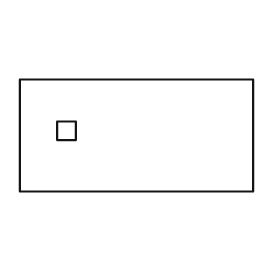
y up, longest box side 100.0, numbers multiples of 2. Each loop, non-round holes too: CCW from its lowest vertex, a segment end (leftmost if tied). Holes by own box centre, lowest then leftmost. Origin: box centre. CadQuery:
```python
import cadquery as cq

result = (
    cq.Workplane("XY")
    .moveTo(-50.0, -24.0)
    .lineTo(50.0, -24.0)
    .lineTo(50.0, 24.0)
    .lineTo(-50.0, 24.0)
    .close()
    .moveTo(-34.0, -2.0)
    .lineTo(-26.0, -2.0)
    .lineTo(-26.0, 6.0)
    .lineTo(-34.0, 6.0)
    .close()
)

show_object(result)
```